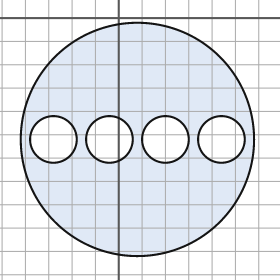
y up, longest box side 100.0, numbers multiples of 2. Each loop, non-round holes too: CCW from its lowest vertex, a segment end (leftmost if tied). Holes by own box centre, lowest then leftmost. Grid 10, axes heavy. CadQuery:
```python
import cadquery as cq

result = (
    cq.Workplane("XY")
    .moveTo(8.0, -52.0)
    .circle(50.0)
    .moveTo(-28.0, -52.0)
    .circle(10.0)
    .moveTo(-4.0, -52.0)
    .circle(10.0)
    .moveTo(20.0, -52.0)
    .circle(10.0)
    .moveTo(44.0, -52.0)
    .circle(10.0)
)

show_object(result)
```